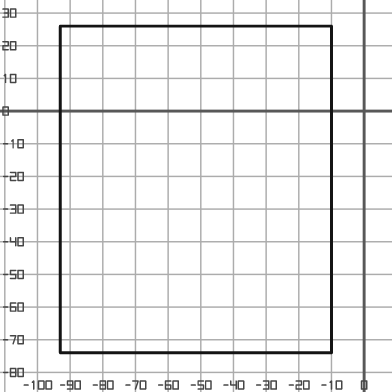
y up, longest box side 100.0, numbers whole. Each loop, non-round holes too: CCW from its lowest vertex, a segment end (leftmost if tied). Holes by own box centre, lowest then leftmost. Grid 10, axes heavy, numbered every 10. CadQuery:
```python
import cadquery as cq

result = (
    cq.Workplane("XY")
    .moveTo(-93.0, -74.0)
    .lineTo(-10.0, -74.0)
    .lineTo(-10.0, 26.0)
    .lineTo(-93.0, 26.0)
    .close()
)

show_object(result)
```